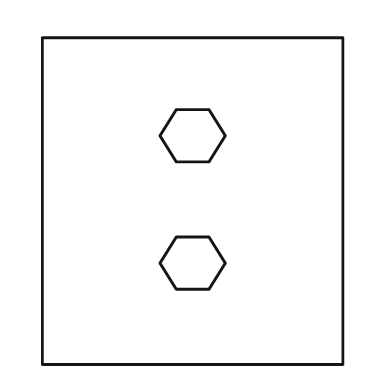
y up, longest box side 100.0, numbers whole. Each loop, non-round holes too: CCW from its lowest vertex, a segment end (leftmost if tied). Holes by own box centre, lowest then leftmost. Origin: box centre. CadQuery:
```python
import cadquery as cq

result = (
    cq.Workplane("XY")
    .moveTo(-46.0, -50.0)
    .lineTo(46.0, -50.0)
    .lineTo(46.0, 50.0)
    .lineTo(-46.0, 50.0)
    .close()
    .moveTo(-5.0, -27.0)
    .lineTo(5.0, -27.0)
    .lineTo(10.0, -19.0)
    .lineTo(5.0, -11.0)
    .lineTo(-5.0, -11.0)
    .lineTo(-10.0, -19.0)
    .close()
    .moveTo(-5.0, 12.0)
    .lineTo(5.0, 12.0)
    .lineTo(10.0, 20.0)
    .lineTo(5.0, 28.0)
    .lineTo(-5.0, 28.0)
    .lineTo(-10.0, 20.0)
    .close()
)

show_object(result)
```